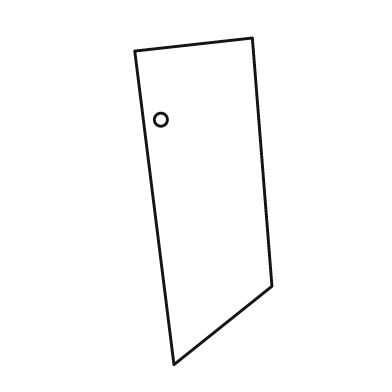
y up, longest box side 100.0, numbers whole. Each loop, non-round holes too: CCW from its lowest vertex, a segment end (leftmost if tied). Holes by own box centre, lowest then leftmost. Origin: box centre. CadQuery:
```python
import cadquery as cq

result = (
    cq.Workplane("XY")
    .moveTo(-9.0, -50.0)
    .lineTo(21.0, -26.0)
    .lineTo(15.0, 50.0)
    .lineTo(-21.0, 46.0)
    .close()
    .moveTo(-13.0, 25.0)
    .circle(2.0)
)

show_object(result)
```